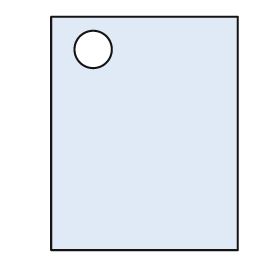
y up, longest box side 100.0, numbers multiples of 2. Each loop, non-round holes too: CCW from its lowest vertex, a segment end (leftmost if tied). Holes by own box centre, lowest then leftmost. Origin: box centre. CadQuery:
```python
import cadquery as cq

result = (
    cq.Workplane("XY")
    .moveTo(-40.0, -50.0)
    .lineTo(40.0, -50.0)
    .lineTo(40.0, 50.0)
    .lineTo(-40.0, 50.0)
    .close()
    .moveTo(-22.0, 36.0)
    .circle(8.0)
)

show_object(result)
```